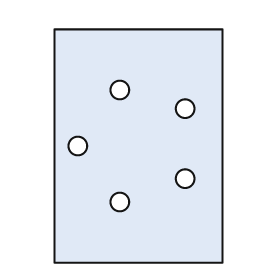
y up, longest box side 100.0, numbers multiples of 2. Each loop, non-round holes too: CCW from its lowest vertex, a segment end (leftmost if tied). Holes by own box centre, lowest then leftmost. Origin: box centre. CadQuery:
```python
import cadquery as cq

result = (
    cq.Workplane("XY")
    .moveTo(-36.0, -50.0)
    .lineTo(36.0, -50.0)
    .lineTo(36.0, 50.0)
    .lineTo(-36.0, 50.0)
    .close()
    .moveTo(-8.0, -24.0)
    .circle(4.0)
    .moveTo(20.0, -14.0)
    .circle(4.0)
    .moveTo(-26.0, 0.0)
    .circle(4.0)
    .moveTo(20.0, 16.0)
    .circle(4.0)
    .moveTo(-8.0, 24.0)
    .circle(4.0)
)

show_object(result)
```